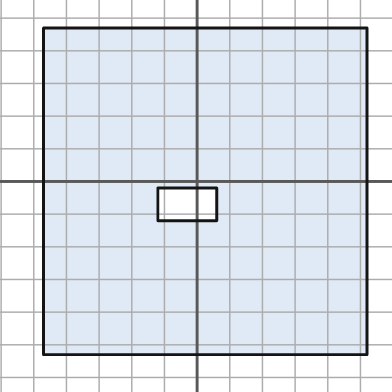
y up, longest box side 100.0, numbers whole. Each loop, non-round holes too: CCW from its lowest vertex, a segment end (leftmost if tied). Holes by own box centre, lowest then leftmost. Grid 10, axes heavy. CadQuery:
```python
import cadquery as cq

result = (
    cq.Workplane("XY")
    .moveTo(-47.0, -53.0)
    .lineTo(52.0, -53.0)
    .lineTo(52.0, 47.0)
    .lineTo(-47.0, 47.0)
    .close()
    .moveTo(-12.0, -12.0)
    .lineTo(6.0, -12.0)
    .lineTo(6.0, -2.0)
    .lineTo(-12.0, -2.0)
    .close()
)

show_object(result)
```